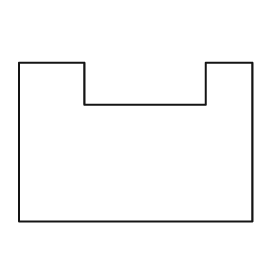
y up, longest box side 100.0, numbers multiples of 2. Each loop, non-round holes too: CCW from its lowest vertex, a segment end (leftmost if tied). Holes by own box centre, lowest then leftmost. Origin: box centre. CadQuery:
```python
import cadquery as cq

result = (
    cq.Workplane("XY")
    .moveTo(-50.0, -34.0)
    .lineTo(50.0, -34.0)
    .lineTo(50.0, 34.0)
    .lineTo(30.0, 34.0)
    .lineTo(30.0, 16.0)
    .lineTo(-22.0, 16.0)
    .lineTo(-22.0, 34.0)
    .lineTo(-50.0, 34.0)
    .close()
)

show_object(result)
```